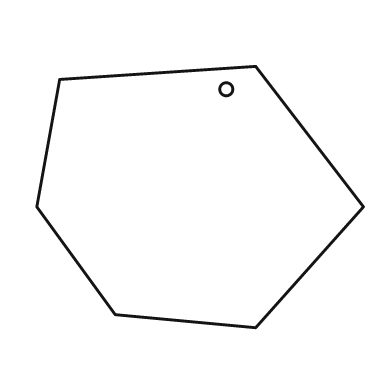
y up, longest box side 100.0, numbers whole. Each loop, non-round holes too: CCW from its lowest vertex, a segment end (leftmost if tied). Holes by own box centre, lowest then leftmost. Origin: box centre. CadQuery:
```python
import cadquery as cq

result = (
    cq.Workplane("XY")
    .moveTo(17.0, -40.0)
    .lineTo(50.0, -3.0)
    .lineTo(17.0, 40.0)
    .lineTo(-43.0, 36.0)
    .lineTo(-50.0, -3.0)
    .lineTo(-26.0, -36.0)
    .close()
    .moveTo(8.0, 33.0)
    .circle(2.0)
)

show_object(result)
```